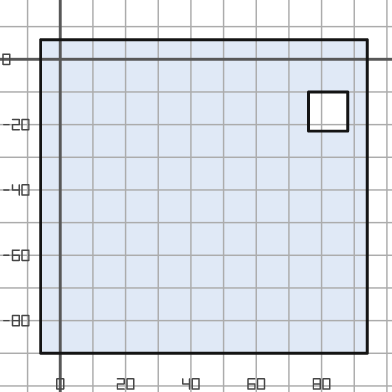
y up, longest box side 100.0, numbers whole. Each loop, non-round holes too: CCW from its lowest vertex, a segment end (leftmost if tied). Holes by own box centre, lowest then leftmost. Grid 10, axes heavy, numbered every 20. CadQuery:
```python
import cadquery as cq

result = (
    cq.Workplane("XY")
    .moveTo(-6.0, -90.0)
    .lineTo(94.0, -90.0)
    .lineTo(94.0, 6.0)
    .lineTo(-6.0, 6.0)
    .close()
    .moveTo(76.0, -22.0)
    .lineTo(88.0, -22.0)
    .lineTo(88.0, -10.0)
    .lineTo(76.0, -10.0)
    .close()
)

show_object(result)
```